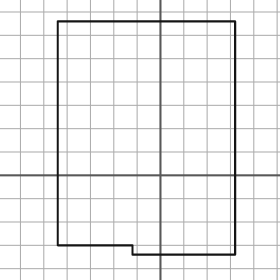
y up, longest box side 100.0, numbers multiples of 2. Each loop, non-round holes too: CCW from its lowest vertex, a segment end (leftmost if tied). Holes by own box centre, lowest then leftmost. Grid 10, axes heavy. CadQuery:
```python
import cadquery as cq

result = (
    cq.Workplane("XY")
    .moveTo(-12.0, -34.0)
    .lineTo(32.0, -34.0)
    .lineTo(32.0, 66.0)
    .lineTo(-44.0, 66.0)
    .lineTo(-44.0, -30.0)
    .lineTo(-12.0, -30.0)
    .close()
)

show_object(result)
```